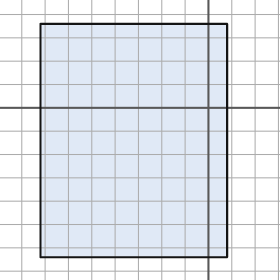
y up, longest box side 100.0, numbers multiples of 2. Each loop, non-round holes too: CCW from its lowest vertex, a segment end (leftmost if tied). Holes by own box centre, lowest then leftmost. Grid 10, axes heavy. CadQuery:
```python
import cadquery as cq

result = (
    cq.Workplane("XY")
    .moveTo(-72.0, -64.0)
    .lineTo(8.0, -64.0)
    .lineTo(8.0, 36.0)
    .lineTo(-72.0, 36.0)
    .close()
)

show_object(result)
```